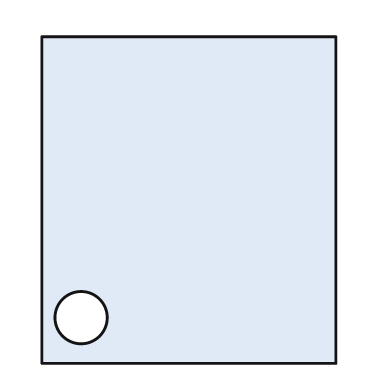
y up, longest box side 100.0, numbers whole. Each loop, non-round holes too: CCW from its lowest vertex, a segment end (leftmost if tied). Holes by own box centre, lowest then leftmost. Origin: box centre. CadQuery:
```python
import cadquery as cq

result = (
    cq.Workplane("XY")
    .moveTo(-45.0, -50.0)
    .lineTo(45.0, -50.0)
    .lineTo(45.0, 50.0)
    .lineTo(-45.0, 50.0)
    .close()
    .moveTo(-33.0, -36.0)
    .circle(8.0)
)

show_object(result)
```